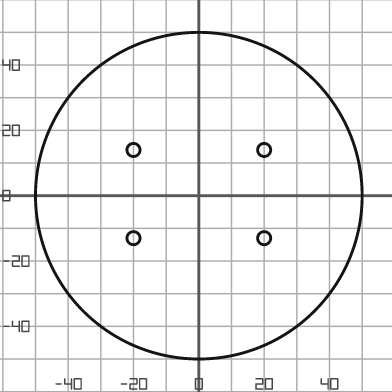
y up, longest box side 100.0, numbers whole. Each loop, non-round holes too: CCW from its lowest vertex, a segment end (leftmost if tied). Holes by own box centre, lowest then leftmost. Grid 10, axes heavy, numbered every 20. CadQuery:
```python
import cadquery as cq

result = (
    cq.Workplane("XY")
    .moveTo(0.0, 0.0)
    .circle(50.0)
    .moveTo(-20.0, -13.0)
    .circle(2.0)
    .moveTo(20.0, -13.0)
    .circle(2.0)
    .moveTo(-20.0, 14.0)
    .circle(2.0)
    .moveTo(20.0, 14.0)
    .circle(2.0)
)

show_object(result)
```